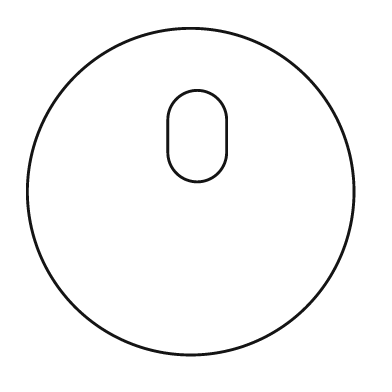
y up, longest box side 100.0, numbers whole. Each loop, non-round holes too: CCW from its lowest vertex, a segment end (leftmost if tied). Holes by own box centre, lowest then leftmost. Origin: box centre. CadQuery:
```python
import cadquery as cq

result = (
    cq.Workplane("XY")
    .moveTo(0.0, 0.0)
    .circle(50.0)
    .moveTo(-7.0, 12.0)
    .threePointArc((2.0, 3.0), (11.0, 12.0))
    .lineTo(11.0, 22.0)
    .threePointArc((2.0, 31.0), (-7.0, 22.0))
    .close()
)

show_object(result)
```